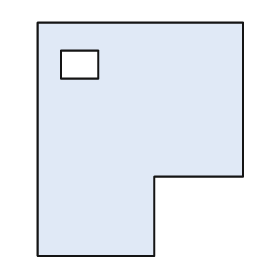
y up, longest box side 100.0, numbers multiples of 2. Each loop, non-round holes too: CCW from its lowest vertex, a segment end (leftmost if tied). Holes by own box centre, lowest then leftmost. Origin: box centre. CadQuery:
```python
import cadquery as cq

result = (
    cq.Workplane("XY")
    .moveTo(-44.0, -50.0)
    .lineTo(6.0, -50.0)
    .lineTo(6.0, -16.0)
    .lineTo(44.0, -16.0)
    .lineTo(44.0, 50.0)
    .lineTo(-44.0, 50.0)
    .close()
    .moveTo(-34.0, 26.0)
    .lineTo(-18.0, 26.0)
    .lineTo(-18.0, 38.0)
    .lineTo(-34.0, 38.0)
    .close()
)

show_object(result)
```